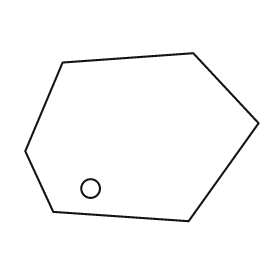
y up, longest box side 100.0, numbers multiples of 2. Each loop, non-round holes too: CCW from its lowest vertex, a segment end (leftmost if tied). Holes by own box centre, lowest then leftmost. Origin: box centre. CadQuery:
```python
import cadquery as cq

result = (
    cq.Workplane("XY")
    .moveTo(20.0, -36.0)
    .lineTo(50.0, 6.0)
    .lineTo(22.0, 36.0)
    .lineTo(-34.0, 32.0)
    .lineTo(-50.0, -6.0)
    .lineTo(-38.0, -32.0)
    .close()
    .moveTo(-22.0, -22.0)
    .circle(4.0)
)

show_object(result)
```